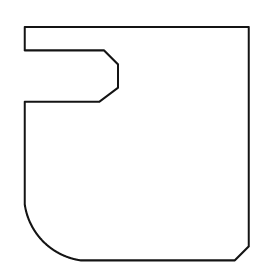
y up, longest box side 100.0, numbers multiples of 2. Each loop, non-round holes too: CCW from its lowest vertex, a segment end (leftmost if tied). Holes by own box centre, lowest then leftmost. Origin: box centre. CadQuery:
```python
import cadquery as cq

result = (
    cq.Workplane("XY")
    .moveTo(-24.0, -50.0)
    .lineTo(42.0, -50.0)
    .lineTo(48.0, -44.0)
    .lineTo(48.0, 50.0)
    .lineTo(-48.0, 50.0)
    .lineTo(-48.0, 40.0)
    .lineTo(-14.0, 40.0)
    .lineTo(-8.0, 34.0)
    .lineTo(-8.0, 24.0)
    .lineTo(-16.0, 18.0)
    .lineTo(-48.0, 18.0)
    .lineTo(-48.0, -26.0)
    .threePointArc((-40.0, -42.0), (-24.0, -50.0))
    .close()
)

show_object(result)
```